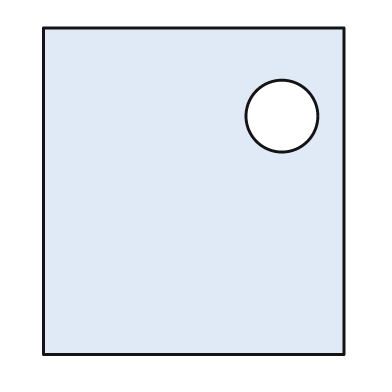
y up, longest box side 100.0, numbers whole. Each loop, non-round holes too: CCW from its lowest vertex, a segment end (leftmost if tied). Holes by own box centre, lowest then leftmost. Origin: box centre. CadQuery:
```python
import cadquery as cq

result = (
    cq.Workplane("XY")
    .moveTo(-46.0, -50.0)
    .lineTo(46.0, -50.0)
    .lineTo(46.0, 50.0)
    .lineTo(-46.0, 50.0)
    .close()
    .moveTo(27.0, 23.0)
    .circle(11.0)
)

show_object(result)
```